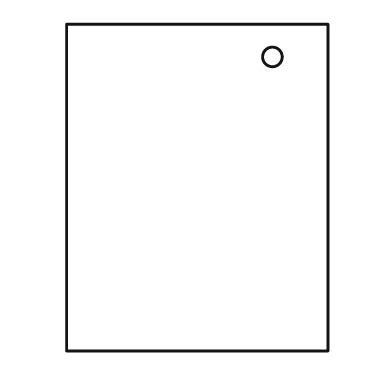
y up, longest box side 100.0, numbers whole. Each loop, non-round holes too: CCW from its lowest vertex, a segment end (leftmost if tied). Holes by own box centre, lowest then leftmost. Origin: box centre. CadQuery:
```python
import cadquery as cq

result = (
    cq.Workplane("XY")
    .moveTo(-40.0, -50.0)
    .lineTo(40.0, -50.0)
    .lineTo(40.0, 50.0)
    .lineTo(-40.0, 50.0)
    .close()
    .moveTo(23.0, 40.0)
    .circle(3.0)
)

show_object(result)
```